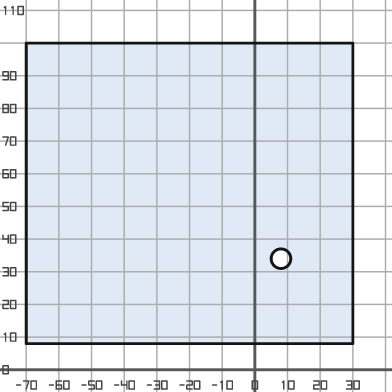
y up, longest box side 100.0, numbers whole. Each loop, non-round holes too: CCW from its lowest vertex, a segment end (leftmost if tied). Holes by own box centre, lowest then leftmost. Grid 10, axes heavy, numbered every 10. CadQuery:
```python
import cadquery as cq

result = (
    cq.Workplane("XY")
    .moveTo(-70.0, 8.0)
    .lineTo(30.0, 8.0)
    .lineTo(30.0, 100.0)
    .lineTo(-70.0, 100.0)
    .close()
    .moveTo(8.0, 34.0)
    .circle(3.0)
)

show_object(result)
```